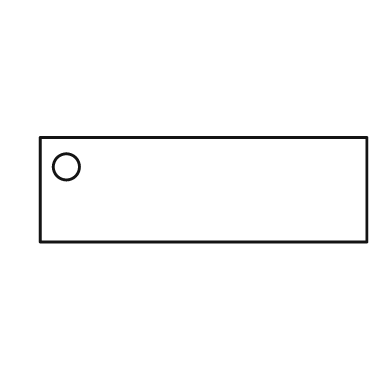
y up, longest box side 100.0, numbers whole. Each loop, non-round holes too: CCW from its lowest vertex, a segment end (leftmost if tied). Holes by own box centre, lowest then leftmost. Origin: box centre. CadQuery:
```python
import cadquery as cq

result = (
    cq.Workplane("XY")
    .moveTo(-50.0, -16.0)
    .lineTo(50.0, -16.0)
    .lineTo(50.0, 16.0)
    .lineTo(-50.0, 16.0)
    .close()
    .moveTo(-42.0, 7.0)
    .circle(4.0)
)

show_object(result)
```